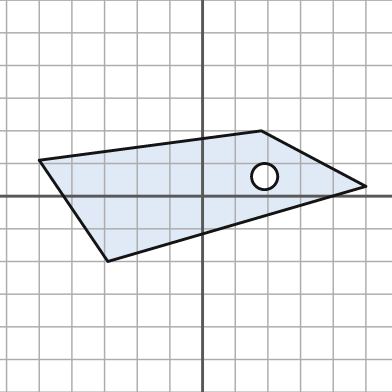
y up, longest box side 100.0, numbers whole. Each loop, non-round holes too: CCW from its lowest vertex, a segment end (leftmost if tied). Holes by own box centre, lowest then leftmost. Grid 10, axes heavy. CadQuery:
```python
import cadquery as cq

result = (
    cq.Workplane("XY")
    .moveTo(-29.0, -20.0)
    .lineTo(50.0, 3.0)
    .lineTo(18.0, 20.0)
    .lineTo(-50.0, 11.0)
    .close()
    .moveTo(19.0, 6.0)
    .circle(4.0)
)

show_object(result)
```